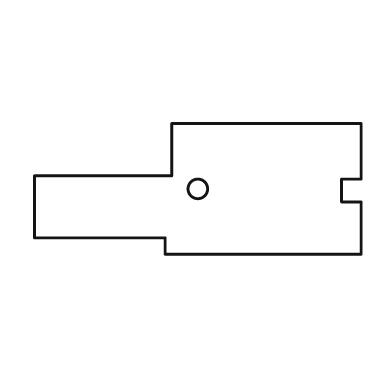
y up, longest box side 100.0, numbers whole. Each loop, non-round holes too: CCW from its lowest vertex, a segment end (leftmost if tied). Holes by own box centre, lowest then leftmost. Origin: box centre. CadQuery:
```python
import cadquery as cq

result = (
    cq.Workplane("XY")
    .moveTo(-10.0, -20.0)
    .lineTo(50.0, -20.0)
    .lineTo(50.0, -4.0)
    .lineTo(44.0, -4.0)
    .lineTo(44.0, 3.0)
    .lineTo(50.0, 3.0)
    .lineTo(50.0, 20.0)
    .lineTo(-8.0, 20.0)
    .lineTo(-8.0, 4.0)
    .lineTo(-50.0, 4.0)
    .lineTo(-50.0, -15.0)
    .lineTo(-10.0, -15.0)
    .close()
    .moveTo(0.0, 0.0)
    .circle(3.0)
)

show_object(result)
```